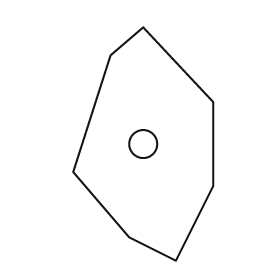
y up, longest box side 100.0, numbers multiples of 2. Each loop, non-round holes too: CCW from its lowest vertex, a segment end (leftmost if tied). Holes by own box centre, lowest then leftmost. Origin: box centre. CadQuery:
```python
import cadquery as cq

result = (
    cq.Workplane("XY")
    .moveTo(14.0, -50.0)
    .lineTo(30.0, -18.0)
    .lineTo(30.0, 18.0)
    .lineTo(0.0, 50.0)
    .lineTo(-14.0, 38.0)
    .lineTo(-30.0, -12.0)
    .lineTo(-6.0, -40.0)
    .close()
    .moveTo(0.0, 0.0)
    .circle(6.0)
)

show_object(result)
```